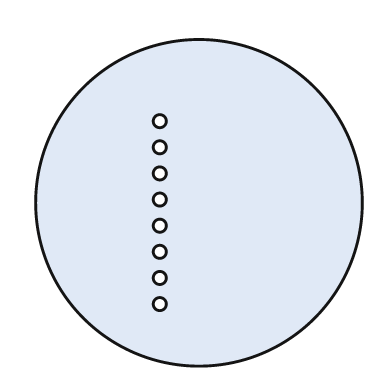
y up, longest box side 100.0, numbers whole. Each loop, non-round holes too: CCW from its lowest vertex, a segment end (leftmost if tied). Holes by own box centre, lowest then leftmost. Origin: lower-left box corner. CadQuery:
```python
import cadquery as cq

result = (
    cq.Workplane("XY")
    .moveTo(50.0, 50.0)
    .circle(50.0)
    .moveTo(38.0, 19.0)
    .circle(2.0)
    .moveTo(38.0, 27.0)
    .circle(2.0)
    .moveTo(38.0, 35.0)
    .circle(2.0)
    .moveTo(38.0, 43.0)
    .circle(2.0)
    .moveTo(38.0, 51.0)
    .circle(2.0)
    .moveTo(38.0, 59.0)
    .circle(2.0)
    .moveTo(38.0, 67.0)
    .circle(2.0)
    .moveTo(38.0, 75.0)
    .circle(2.0)
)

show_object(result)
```